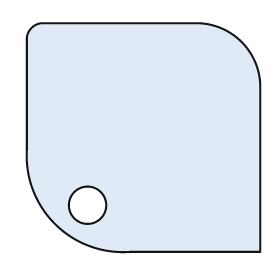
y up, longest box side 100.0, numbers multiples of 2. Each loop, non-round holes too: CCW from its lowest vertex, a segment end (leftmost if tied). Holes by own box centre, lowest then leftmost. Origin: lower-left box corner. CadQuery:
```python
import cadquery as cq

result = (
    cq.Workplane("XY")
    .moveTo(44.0, 0.0)
    .lineTo(100.0, 0.0)
    .lineTo(100.0, 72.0)
    .threePointArc((92.0, 90.0), (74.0, 98.0))
    .lineTo(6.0, 98.0)
    .threePointArc((2.0, 96.0), (0.0, 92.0))
    .lineTo(0.0, 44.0)
    .threePointArc((12.0, 12.0), (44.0, 0.0))
    .close()
    .moveTo(26.0, 20.0)
    .circle(8.0)
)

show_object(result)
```